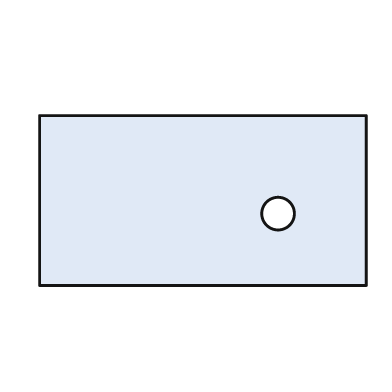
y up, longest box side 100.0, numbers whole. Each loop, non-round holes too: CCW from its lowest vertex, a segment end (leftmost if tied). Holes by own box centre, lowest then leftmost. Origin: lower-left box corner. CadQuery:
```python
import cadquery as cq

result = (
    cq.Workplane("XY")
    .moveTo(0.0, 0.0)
    .lineTo(100.0, 0.0)
    .lineTo(100.0, 52.0)
    .lineTo(0.0, 52.0)
    .close()
    .moveTo(73.0, 22.0)
    .circle(5.0)
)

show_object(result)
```